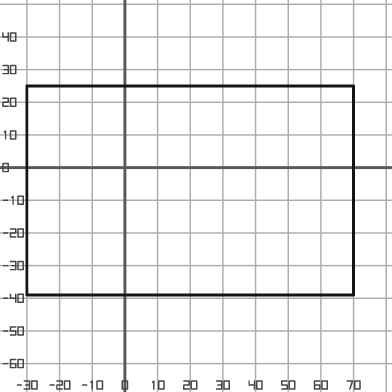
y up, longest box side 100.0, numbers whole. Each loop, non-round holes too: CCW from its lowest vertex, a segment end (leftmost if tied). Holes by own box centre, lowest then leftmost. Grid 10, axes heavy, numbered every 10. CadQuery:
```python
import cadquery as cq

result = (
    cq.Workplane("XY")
    .moveTo(-30.0, -39.0)
    .lineTo(70.0, -39.0)
    .lineTo(70.0, 25.0)
    .lineTo(-30.0, 25.0)
    .close()
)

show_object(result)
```